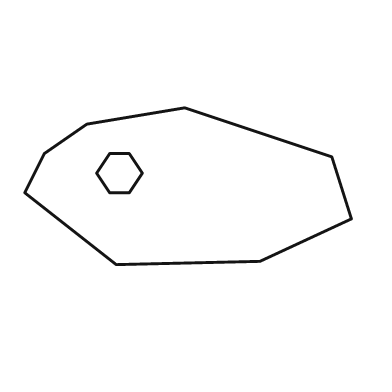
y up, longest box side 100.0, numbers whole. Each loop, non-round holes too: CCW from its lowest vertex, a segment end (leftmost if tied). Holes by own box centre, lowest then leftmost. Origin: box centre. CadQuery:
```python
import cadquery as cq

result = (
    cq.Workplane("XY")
    .moveTo(-22.0, -24.0)
    .lineTo(22.0, -23.0)
    .lineTo(50.0, -10.0)
    .lineTo(44.0, 9.0)
    .lineTo(-1.0, 24.0)
    .lineTo(-31.0, 19.0)
    .lineTo(-44.0, 10.0)
    .lineTo(-50.0, -2.0)
    .close()
    .moveTo(-24.0, -2.0)
    .lineTo(-18.0, -2.0)
    .lineTo(-14.0, 4.0)
    .lineTo(-18.0, 10.0)
    .lineTo(-24.0, 10.0)
    .lineTo(-28.0, 4.0)
    .close()
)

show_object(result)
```